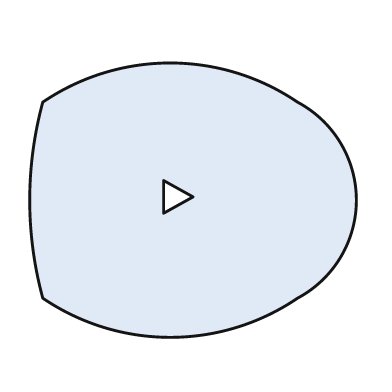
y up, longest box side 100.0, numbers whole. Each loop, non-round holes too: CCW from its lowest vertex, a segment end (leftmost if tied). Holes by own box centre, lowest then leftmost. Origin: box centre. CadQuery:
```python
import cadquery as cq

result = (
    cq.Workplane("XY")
    .moveTo(-46.0, -30.0)
    .threePointArc((-7.0, -42.0), (32.0, -30.0))
    .threePointArc((50.0, 0.0), (32.0, 30.0))
    .threePointArc((-7.0, 42.0), (-46.0, 30.0))
    .threePointArc((-50.0, 0.0), (-46.0, -30.0))
    .close()
    .moveTo(-9.0, -4.0)
    .lineTo(0.0, 1.0)
    .lineTo(-9.0, 6.0)
    .close()
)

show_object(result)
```